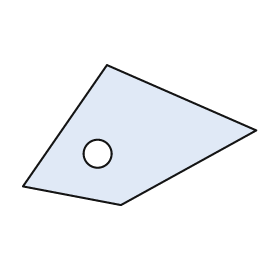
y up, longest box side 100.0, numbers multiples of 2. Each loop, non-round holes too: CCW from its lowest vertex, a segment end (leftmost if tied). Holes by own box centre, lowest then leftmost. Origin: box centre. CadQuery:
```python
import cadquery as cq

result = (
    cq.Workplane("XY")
    .moveTo(-8.0, -30.0)
    .lineTo(50.0, 2.0)
    .lineTo(-14.0, 30.0)
    .lineTo(-50.0, -22.0)
    .close()
    .moveTo(-18.0, -8.0)
    .circle(6.0)
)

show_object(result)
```